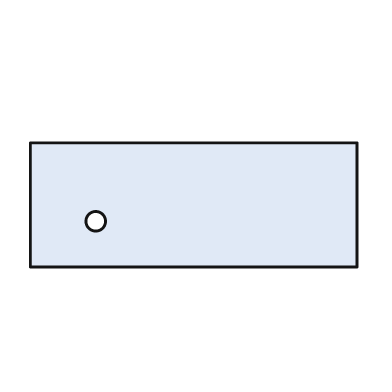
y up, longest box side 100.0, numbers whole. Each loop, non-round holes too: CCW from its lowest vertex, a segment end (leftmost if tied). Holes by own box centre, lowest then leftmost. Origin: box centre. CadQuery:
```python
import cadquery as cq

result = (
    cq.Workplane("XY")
    .moveTo(-50.0, -19.0)
    .lineTo(50.0, -19.0)
    .lineTo(50.0, 19.0)
    .lineTo(-50.0, 19.0)
    .close()
    .moveTo(-30.0, -5.0)
    .circle(3.0)
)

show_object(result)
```